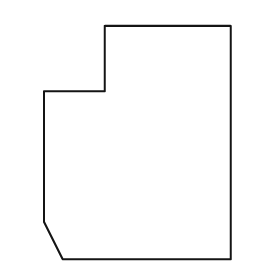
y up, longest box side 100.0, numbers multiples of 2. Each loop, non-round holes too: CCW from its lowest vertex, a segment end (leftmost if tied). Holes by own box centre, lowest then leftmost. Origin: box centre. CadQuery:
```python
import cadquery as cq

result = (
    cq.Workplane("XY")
    .moveTo(-32.0, -50.0)
    .lineTo(40.0, -50.0)
    .lineTo(40.0, 50.0)
    .lineTo(-14.0, 50.0)
    .lineTo(-14.0, 22.0)
    .lineTo(-40.0, 22.0)
    .lineTo(-40.0, -34.0)
    .close()
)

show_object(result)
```